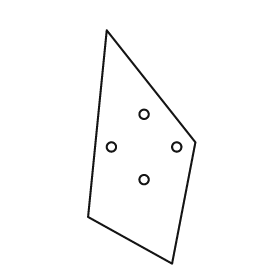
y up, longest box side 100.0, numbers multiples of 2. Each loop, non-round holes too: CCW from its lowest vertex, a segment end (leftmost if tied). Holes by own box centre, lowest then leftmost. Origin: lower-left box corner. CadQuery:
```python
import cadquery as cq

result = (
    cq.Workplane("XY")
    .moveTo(36.0, 0.0)
    .lineTo(46.0, 52.0)
    .lineTo(8.0, 100.0)
    .lineTo(0.0, 20.0)
    .close()
    .moveTo(24.0, 36.0)
    .circle(2.0)
    .moveTo(10.0, 50.0)
    .circle(2.0)
    .moveTo(38.0, 50.0)
    .circle(2.0)
    .moveTo(24.0, 64.0)
    .circle(2.0)
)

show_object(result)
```